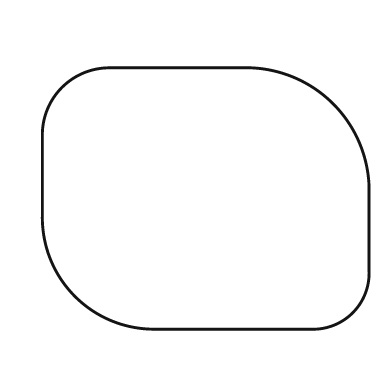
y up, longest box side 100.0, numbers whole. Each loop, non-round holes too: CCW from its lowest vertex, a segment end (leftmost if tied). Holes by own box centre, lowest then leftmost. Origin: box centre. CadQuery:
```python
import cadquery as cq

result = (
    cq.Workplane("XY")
    .moveTo(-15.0, -40.0)
    .lineTo(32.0, -40.0)
    .threePointArc((45.0, -35.0), (50.0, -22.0))
    .lineTo(50.0, 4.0)
    .threePointArc((39.0, 29.0), (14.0, 40.0))
    .lineTo(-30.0, 40.0)
    .threePointArc((-44.0, 34.0), (-50.0, 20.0))
    .lineTo(-50.0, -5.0)
    .threePointArc((-40.0, -30.0), (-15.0, -40.0))
    .close()
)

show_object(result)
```